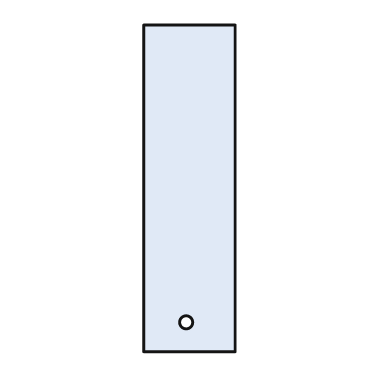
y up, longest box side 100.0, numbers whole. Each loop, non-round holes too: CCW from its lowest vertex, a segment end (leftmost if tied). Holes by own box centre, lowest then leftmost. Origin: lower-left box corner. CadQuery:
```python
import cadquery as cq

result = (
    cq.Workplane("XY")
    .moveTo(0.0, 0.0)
    .lineTo(28.0, 0.0)
    .lineTo(28.0, 100.0)
    .lineTo(0.0, 100.0)
    .close()
    .moveTo(13.0, 9.0)
    .circle(2.0)
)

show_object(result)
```